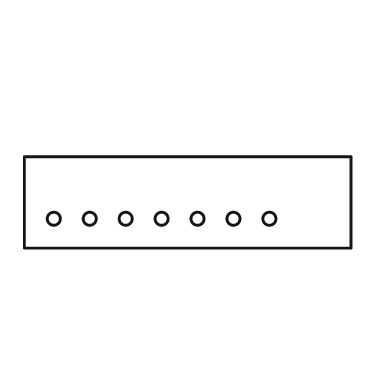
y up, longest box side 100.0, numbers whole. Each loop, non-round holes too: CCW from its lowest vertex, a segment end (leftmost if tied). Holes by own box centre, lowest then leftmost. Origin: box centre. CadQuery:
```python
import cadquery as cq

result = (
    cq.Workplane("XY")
    .moveTo(-50.0, -14.0)
    .lineTo(50.0, -14.0)
    .lineTo(50.0, 14.0)
    .lineTo(-50.0, 14.0)
    .close()
    .moveTo(-41.0, -5.0)
    .circle(2.0)
    .moveTo(-30.0, -5.0)
    .circle(2.0)
    .moveTo(-19.0, -5.0)
    .circle(2.0)
    .moveTo(-8.0, -5.0)
    .circle(2.0)
    .moveTo(3.0, -5.0)
    .circle(2.0)
    .moveTo(14.0, -5.0)
    .circle(2.0)
    .moveTo(25.0, -5.0)
    .circle(2.0)
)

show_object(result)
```